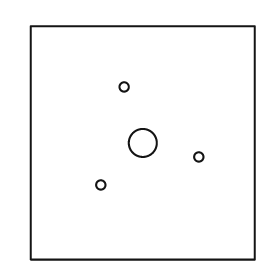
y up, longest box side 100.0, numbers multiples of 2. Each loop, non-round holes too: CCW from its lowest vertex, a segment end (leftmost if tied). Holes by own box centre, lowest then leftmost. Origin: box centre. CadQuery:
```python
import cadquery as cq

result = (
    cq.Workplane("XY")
    .moveTo(-48.0, -50.0)
    .lineTo(48.0, -50.0)
    .lineTo(48.0, 50.0)
    .lineTo(-48.0, 50.0)
    .close()
    .moveTo(-18.0, -18.0)
    .circle(2.0)
    .moveTo(24.0, -6.0)
    .circle(2.0)
    .moveTo(0.0, 0.0)
    .circle(6.0)
    .moveTo(-8.0, 24.0)
    .circle(2.0)
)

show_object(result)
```